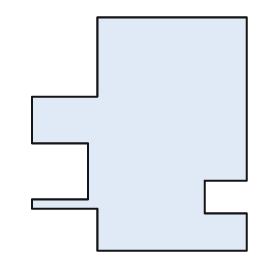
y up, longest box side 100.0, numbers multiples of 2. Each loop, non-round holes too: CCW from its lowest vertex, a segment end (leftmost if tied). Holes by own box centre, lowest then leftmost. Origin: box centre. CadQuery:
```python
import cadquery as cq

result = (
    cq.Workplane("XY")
    .moveTo(-18.0, -50.0)
    .lineTo(46.0, -50.0)
    .lineTo(46.0, -34.0)
    .lineTo(28.0, -34.0)
    .lineTo(28.0, -20.0)
    .lineTo(46.0, -20.0)
    .lineTo(46.0, 50.0)
    .lineTo(-18.0, 50.0)
    .lineTo(-18.0, 16.0)
    .lineTo(-46.0, 16.0)
    .lineTo(-46.0, -4.0)
    .lineTo(-22.0, -4.0)
    .lineTo(-22.0, -28.0)
    .lineTo(-46.0, -28.0)
    .lineTo(-46.0, -32.0)
    .lineTo(-18.0, -32.0)
    .close()
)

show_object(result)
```